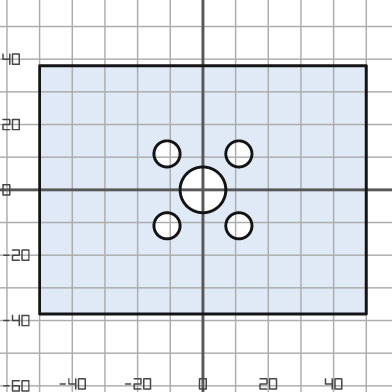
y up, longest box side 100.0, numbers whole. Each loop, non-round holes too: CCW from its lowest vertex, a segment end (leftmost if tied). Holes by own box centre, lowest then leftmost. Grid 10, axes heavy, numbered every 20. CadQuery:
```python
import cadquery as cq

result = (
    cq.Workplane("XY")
    .moveTo(-50.0, -38.0)
    .lineTo(50.0, -38.0)
    .lineTo(50.0, 38.0)
    .lineTo(-50.0, 38.0)
    .close()
    .moveTo(-11.0, -11.0)
    .circle(4.0)
    .moveTo(11.0, -11.0)
    .circle(4.0)
    .moveTo(0.0, 0.0)
    .circle(7.0)
    .moveTo(-11.0, 11.0)
    .circle(4.0)
    .moveTo(11.0, 11.0)
    .circle(4.0)
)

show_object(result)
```